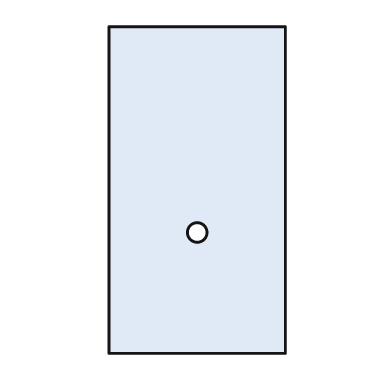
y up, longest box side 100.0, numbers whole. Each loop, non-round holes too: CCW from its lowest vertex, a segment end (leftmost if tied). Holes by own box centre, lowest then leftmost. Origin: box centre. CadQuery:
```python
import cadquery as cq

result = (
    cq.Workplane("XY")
    .moveTo(-27.0, -50.0)
    .lineTo(27.0, -50.0)
    .lineTo(27.0, 50.0)
    .lineTo(-27.0, 50.0)
    .close()
    .moveTo(0.0, -13.0)
    .circle(3.0)
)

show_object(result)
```